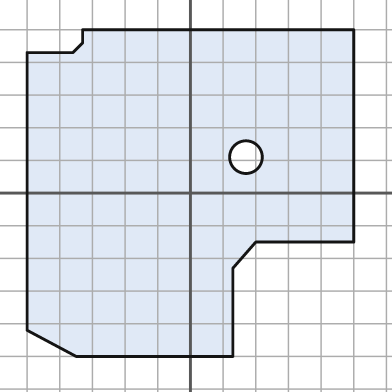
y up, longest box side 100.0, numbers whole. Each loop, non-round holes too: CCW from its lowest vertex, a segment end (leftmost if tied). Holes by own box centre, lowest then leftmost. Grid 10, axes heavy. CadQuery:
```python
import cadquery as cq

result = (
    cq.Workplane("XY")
    .moveTo(-35.0, -50.0)
    .lineTo(13.0, -50.0)
    .lineTo(13.0, -23.0)
    .lineTo(20.0, -15.0)
    .lineTo(50.0, -15.0)
    .lineTo(50.0, 50.0)
    .lineTo(-33.0, 50.0)
    .lineTo(-33.0, 46.0)
    .lineTo(-36.0, 43.0)
    .lineTo(-50.0, 43.0)
    .lineTo(-50.0, -42.0)
    .close()
    .moveTo(17.0, 11.0)
    .circle(5.0)
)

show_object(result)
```